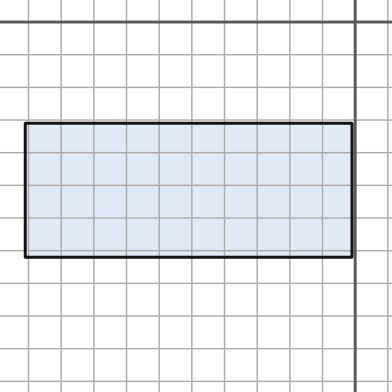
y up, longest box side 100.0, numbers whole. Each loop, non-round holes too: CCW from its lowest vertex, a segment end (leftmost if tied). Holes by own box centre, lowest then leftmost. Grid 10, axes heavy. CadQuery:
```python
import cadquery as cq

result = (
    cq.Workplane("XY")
    .moveTo(-101.0, -72.0)
    .lineTo(-1.0, -72.0)
    .lineTo(-1.0, -31.0)
    .lineTo(-101.0, -31.0)
    .close()
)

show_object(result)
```